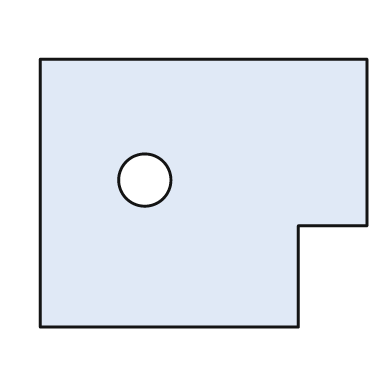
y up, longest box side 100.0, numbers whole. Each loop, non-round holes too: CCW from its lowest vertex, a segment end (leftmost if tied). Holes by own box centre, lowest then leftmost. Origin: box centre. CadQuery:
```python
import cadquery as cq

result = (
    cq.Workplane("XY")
    .moveTo(-50.0, -41.0)
    .lineTo(29.0, -41.0)
    .lineTo(29.0, -10.0)
    .lineTo(50.0, -10.0)
    .lineTo(50.0, 41.0)
    .lineTo(-50.0, 41.0)
    .close()
    .moveTo(-18.0, 4.0)
    .circle(8.0)
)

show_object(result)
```